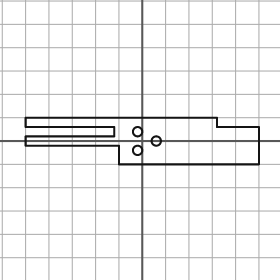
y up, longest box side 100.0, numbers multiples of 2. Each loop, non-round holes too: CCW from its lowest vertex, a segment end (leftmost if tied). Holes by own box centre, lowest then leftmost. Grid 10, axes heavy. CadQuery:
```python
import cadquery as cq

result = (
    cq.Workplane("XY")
    .moveTo(-10.0, -10.0)
    .lineTo(50.0, -10.0)
    .lineTo(50.0, 6.0)
    .lineTo(32.0, 6.0)
    .lineTo(32.0, 10.0)
    .lineTo(-50.0, 10.0)
    .lineTo(-50.0, 6.0)
    .lineTo(-12.0, 6.0)
    .lineTo(-12.0, 2.0)
    .lineTo(-50.0, 2.0)
    .lineTo(-50.0, -2.0)
    .lineTo(-10.0, -2.0)
    .close()
    .moveTo(-2.0, -4.0)
    .circle(2.0)
    .moveTo(6.0, 0.0)
    .circle(2.0)
    .moveTo(-2.0, 4.0)
    .circle(2.0)
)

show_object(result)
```